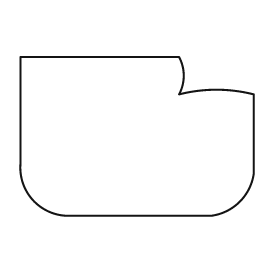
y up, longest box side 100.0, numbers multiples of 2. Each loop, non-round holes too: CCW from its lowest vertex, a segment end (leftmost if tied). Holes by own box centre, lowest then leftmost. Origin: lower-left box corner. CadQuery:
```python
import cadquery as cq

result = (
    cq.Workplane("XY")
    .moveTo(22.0, 0.0)
    .lineTo(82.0, 0.0)
    .threePointArc((94.0, 6.0), (100.0, 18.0))
    .lineTo(100.0, 52.0)
    .threePointArc((84.0, 54.0), (68.0, 52.0))
    .threePointArc((70.0, 60.0), (68.0, 68.0))
    .lineTo(0.0, 68.0)
    .lineTo(0.0, 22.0)
    .threePointArc((6.0, 6.0), (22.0, 0.0))
    .close()
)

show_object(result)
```